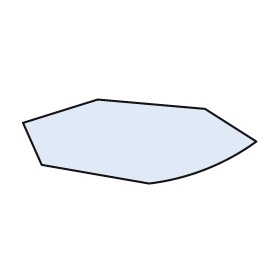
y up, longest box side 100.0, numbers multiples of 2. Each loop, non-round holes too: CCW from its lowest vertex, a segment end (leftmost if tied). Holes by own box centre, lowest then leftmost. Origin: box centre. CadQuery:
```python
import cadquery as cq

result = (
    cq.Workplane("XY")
    .moveTo(4.0, -18.0)
    .threePointArc((28.0, -12.0), (50.0, 0.0))
    .lineTo(28.0, 14.0)
    .lineTo(-18.0, 18.0)
    .lineTo(-50.0, 8.0)
    .lineTo(-42.0, -10.0)
    .close()
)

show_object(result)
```